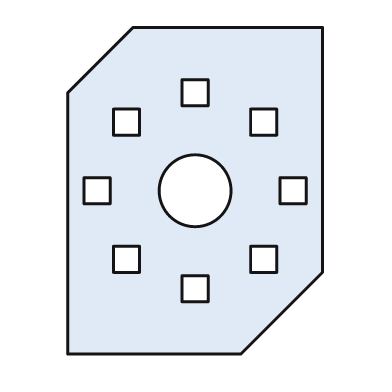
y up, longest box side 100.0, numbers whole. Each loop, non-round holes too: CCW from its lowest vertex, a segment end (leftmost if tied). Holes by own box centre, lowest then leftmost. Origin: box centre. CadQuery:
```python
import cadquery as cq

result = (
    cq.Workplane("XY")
    .moveTo(-39.0, -50.0)
    .lineTo(14.0, -50.0)
    .lineTo(39.0, -25.0)
    .lineTo(39.0, 50.0)
    .lineTo(-19.0, 50.0)
    .lineTo(-39.0, 30.0)
    .close()
    .moveTo(-4.0, -34.0)
    .lineTo(4.0, -34.0)
    .lineTo(4.0, -26.0)
    .lineTo(-4.0, -26.0)
    .close()
    .moveTo(-25.0, -25.0)
    .lineTo(-17.0, -25.0)
    .lineTo(-17.0, -17.0)
    .lineTo(-25.0, -17.0)
    .close()
    .moveTo(17.0, -25.0)
    .lineTo(25.0, -25.0)
    .lineTo(25.0, -17.0)
    .lineTo(17.0, -17.0)
    .close()
    .moveTo(-34.0, -4.0)
    .lineTo(-26.0, -4.0)
    .lineTo(-26.0, 4.0)
    .lineTo(-34.0, 4.0)
    .close()
    .moveTo(0.0, 0.0)
    .circle(11.0)
    .moveTo(26.0, -4.0)
    .lineTo(34.0, -4.0)
    .lineTo(34.0, 4.0)
    .lineTo(26.0, 4.0)
    .close()
    .moveTo(-25.0, 17.0)
    .lineTo(-17.0, 17.0)
    .lineTo(-17.0, 25.0)
    .lineTo(-25.0, 25.0)
    .close()
    .moveTo(17.0, 17.0)
    .lineTo(25.0, 17.0)
    .lineTo(25.0, 25.0)
    .lineTo(17.0, 25.0)
    .close()
    .moveTo(-4.0, 26.0)
    .lineTo(4.0, 26.0)
    .lineTo(4.0, 34.0)
    .lineTo(-4.0, 34.0)
    .close()
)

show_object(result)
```